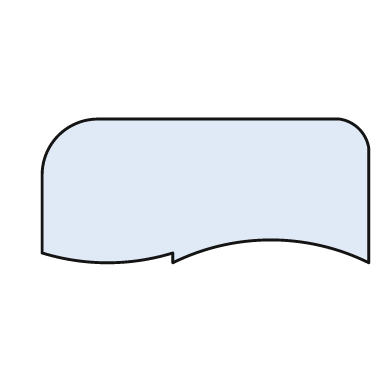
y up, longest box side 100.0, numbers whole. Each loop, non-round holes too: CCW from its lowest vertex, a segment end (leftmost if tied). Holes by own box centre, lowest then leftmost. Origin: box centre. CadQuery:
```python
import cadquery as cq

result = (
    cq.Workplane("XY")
    .moveTo(-10.0, -22.0)
    .threePointArc((20.0, -15.0), (50.0, -22.0))
    .lineTo(50.0, 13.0)
    .threePointArc((47.0, 19.0), (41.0, 22.0))
    .lineTo(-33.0, 22.0)
    .threePointArc((-45.0, 17.0), (-50.0, 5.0))
    .lineTo(-50.0, -19.0)
    .threePointArc((-30.0, -22.0), (-10.0, -19.0))
    .close()
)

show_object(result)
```